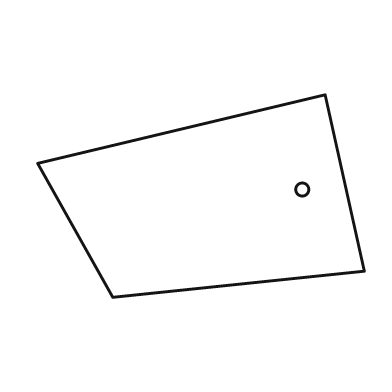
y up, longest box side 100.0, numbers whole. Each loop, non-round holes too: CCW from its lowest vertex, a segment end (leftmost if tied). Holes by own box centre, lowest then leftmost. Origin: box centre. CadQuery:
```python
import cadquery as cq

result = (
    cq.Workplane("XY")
    .moveTo(-27.0, -31.0)
    .lineTo(50.0, -23.0)
    .lineTo(38.0, 31.0)
    .lineTo(-50.0, 10.0)
    .close()
    .moveTo(31.0, 2.0)
    .circle(2.0)
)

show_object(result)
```